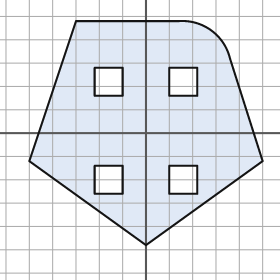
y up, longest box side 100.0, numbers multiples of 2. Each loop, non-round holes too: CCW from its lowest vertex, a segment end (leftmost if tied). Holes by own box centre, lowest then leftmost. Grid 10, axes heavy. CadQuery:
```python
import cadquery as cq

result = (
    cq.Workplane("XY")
    .moveTo(0.0, -48.0)
    .lineTo(50.0, -12.0)
    .lineTo(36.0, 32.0)
    .threePointArc((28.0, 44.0), (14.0, 48.0))
    .lineTo(-30.0, 48.0)
    .lineTo(-50.0, -12.0)
    .close()
    .moveTo(-22.0, -26.0)
    .lineTo(-10.0, -26.0)
    .lineTo(-10.0, -14.0)
    .lineTo(-22.0, -14.0)
    .close()
    .moveTo(10.0, -26.0)
    .lineTo(22.0, -26.0)
    .lineTo(22.0, -14.0)
    .lineTo(10.0, -14.0)
    .close()
    .moveTo(-22.0, 16.0)
    .lineTo(-10.0, 16.0)
    .lineTo(-10.0, 28.0)
    .lineTo(-22.0, 28.0)
    .close()
    .moveTo(10.0, 16.0)
    .lineTo(22.0, 16.0)
    .lineTo(22.0, 28.0)
    .lineTo(10.0, 28.0)
    .close()
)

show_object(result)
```